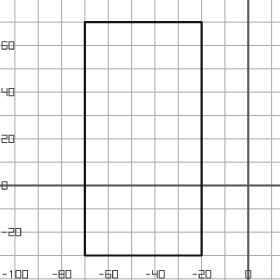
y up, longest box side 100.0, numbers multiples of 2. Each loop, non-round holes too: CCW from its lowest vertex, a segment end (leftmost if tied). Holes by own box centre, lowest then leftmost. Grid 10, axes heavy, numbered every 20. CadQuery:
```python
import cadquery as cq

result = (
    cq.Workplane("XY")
    .moveTo(-70.0, -30.0)
    .lineTo(-20.0, -30.0)
    .lineTo(-20.0, 70.0)
    .lineTo(-70.0, 70.0)
    .close()
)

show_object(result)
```